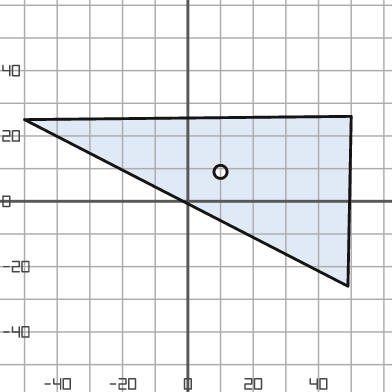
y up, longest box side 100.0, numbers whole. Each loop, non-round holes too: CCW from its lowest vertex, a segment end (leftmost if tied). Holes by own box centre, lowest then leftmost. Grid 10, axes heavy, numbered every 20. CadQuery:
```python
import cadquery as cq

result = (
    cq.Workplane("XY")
    .moveTo(49.0, -26.0)
    .lineTo(50.0, 26.0)
    .lineTo(-50.0, 25.0)
    .close()
    .moveTo(10.0, 9.0)
    .circle(2.0)
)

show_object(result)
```